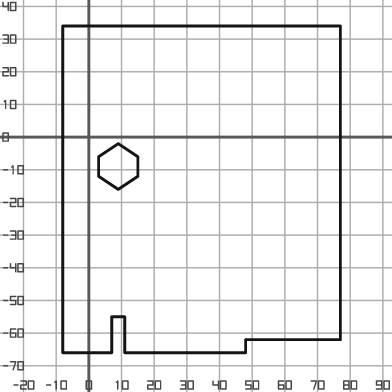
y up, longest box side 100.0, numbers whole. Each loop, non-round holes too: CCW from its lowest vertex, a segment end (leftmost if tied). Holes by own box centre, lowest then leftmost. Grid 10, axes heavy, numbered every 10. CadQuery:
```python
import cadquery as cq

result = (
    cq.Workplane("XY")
    .moveTo(-8.0, -66.0)
    .lineTo(7.0, -66.0)
    .lineTo(7.0, -55.0)
    .lineTo(11.0, -55.0)
    .lineTo(11.0, -66.0)
    .lineTo(48.0, -66.0)
    .lineTo(48.0, -62.0)
    .lineTo(77.0, -62.0)
    .lineTo(77.0, 34.0)
    .lineTo(-8.0, 34.0)
    .close()
    .moveTo(9.0, -16.0)
    .lineTo(15.0, -12.0)
    .lineTo(15.0, -6.0)
    .lineTo(9.0, -2.0)
    .lineTo(3.0, -6.0)
    .lineTo(3.0, -12.0)
    .close()
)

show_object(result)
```